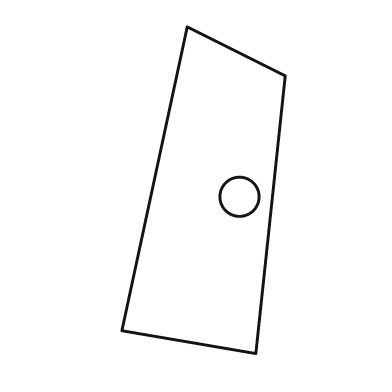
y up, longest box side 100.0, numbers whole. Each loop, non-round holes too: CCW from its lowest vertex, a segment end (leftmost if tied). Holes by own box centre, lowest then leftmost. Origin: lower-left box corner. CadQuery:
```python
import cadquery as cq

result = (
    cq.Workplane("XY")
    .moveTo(41.0, 0.0)
    .lineTo(50.0, 85.0)
    .lineTo(20.0, 100.0)
    .lineTo(0.0, 7.0)
    .close()
    .moveTo(36.0, 48.0)
    .circle(6.0)
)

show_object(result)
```